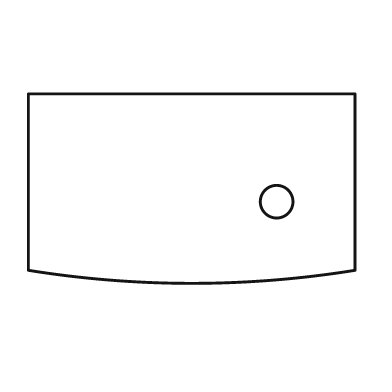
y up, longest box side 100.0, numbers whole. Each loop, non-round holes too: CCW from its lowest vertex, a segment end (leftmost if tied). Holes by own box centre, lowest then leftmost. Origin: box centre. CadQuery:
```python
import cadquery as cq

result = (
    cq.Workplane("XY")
    .moveTo(-50.0, -25.0)
    .threePointArc((0.0, -29.0), (50.0, -25.0))
    .lineTo(50.0, 29.0)
    .lineTo(-50.0, 29.0)
    .close()
    .moveTo(26.0, -4.0)
    .circle(5.0)
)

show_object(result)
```